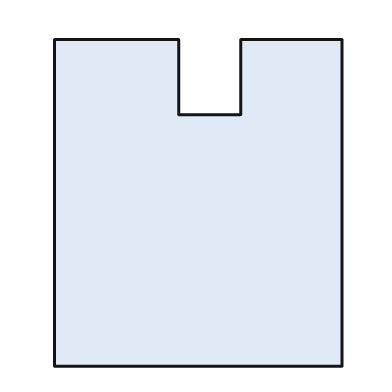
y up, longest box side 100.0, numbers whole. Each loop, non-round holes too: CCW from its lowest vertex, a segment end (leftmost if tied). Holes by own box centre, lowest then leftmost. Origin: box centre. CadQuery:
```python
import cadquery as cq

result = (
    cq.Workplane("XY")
    .moveTo(-44.0, -50.0)
    .lineTo(44.0, -50.0)
    .lineTo(44.0, 50.0)
    .lineTo(13.0, 50.0)
    .lineTo(13.0, 27.0)
    .lineTo(-6.0, 27.0)
    .lineTo(-6.0, 50.0)
    .lineTo(-44.0, 50.0)
    .close()
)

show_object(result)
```